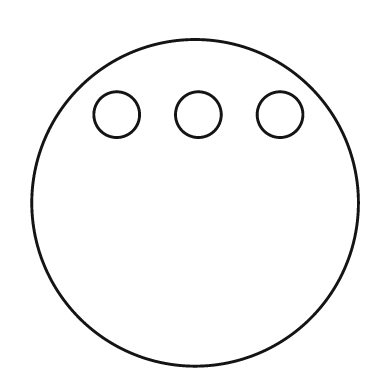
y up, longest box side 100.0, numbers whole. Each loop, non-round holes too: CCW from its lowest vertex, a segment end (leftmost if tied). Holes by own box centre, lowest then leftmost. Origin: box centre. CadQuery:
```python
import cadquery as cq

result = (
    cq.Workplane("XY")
    .moveTo(0.0, 0.0)
    .circle(50.0)
    .moveTo(-24.0, 27.0)
    .circle(7.0)
    .moveTo(1.0, 27.0)
    .circle(7.0)
    .moveTo(26.0, 27.0)
    .circle(7.0)
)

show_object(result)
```